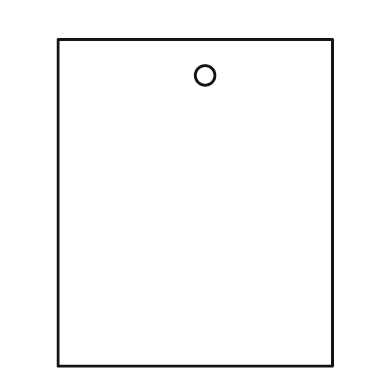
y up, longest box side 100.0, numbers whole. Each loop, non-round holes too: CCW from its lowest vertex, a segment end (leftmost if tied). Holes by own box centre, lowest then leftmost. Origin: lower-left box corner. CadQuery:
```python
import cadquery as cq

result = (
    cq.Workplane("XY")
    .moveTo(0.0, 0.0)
    .lineTo(84.0, 0.0)
    .lineTo(84.0, 100.0)
    .lineTo(0.0, 100.0)
    .close()
    .moveTo(45.0, 89.0)
    .circle(3.0)
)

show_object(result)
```